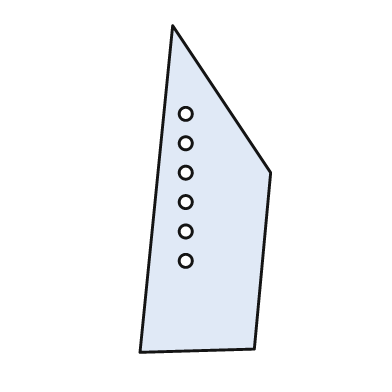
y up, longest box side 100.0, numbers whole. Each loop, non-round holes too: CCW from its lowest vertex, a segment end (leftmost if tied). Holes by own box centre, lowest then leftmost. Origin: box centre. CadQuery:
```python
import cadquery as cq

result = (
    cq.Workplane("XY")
    .moveTo(-20.0, -50.0)
    .lineTo(15.0, -49.0)
    .lineTo(20.0, 5.0)
    .lineTo(-10.0, 50.0)
    .close()
    .moveTo(-6.0, -22.0)
    .circle(2.0)
    .moveTo(-6.0, -13.0)
    .circle(2.0)
    .moveTo(-6.0, -4.0)
    .circle(2.0)
    .moveTo(-6.0, 5.0)
    .circle(2.0)
    .moveTo(-6.0, 14.0)
    .circle(2.0)
    .moveTo(-6.0, 23.0)
    .circle(2.0)
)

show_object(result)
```